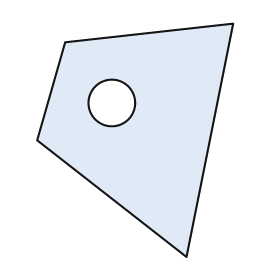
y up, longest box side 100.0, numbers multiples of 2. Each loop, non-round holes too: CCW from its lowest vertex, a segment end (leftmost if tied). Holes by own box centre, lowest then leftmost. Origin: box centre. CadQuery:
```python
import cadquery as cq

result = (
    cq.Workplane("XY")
    .moveTo(22.0, -50.0)
    .lineTo(42.0, 50.0)
    .lineTo(-30.0, 42.0)
    .lineTo(-42.0, 0.0)
    .close()
    .moveTo(-10.0, 16.0)
    .circle(10.0)
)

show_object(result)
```